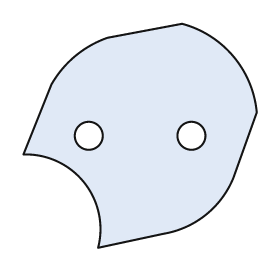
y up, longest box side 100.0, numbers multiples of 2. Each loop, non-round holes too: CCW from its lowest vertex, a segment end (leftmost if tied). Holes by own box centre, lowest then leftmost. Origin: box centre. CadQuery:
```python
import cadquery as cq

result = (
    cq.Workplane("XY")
    .moveTo(-18.0, -48.0)
    .lineTo(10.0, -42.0)
    .threePointArc((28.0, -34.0), (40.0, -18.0))
    .lineTo(50.0, 10.0)
    .threePointArc((40.0, 34.0), (18.0, 48.0))
    .lineTo(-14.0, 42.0)
    .threePointArc((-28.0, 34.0), (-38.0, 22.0))
    .lineTo(-50.0, -8.0)
    .threePointArc((-24.0, -20.0), (-18.0, -48.0))
    .close()
    .moveTo(-22.0, 0.0)
    .circle(6.0)
    .moveTo(22.0, 0.0)
    .circle(6.0)
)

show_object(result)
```